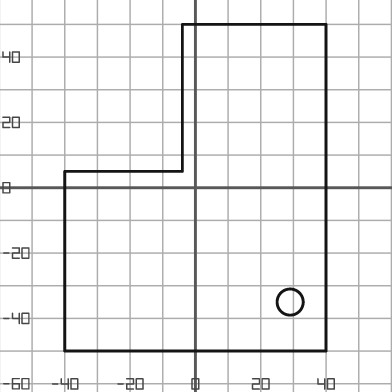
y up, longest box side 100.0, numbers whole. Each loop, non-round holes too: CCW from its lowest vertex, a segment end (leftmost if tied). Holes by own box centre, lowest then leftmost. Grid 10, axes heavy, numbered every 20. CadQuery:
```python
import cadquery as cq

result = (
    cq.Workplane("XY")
    .moveTo(-40.0, -50.0)
    .lineTo(40.0, -50.0)
    .lineTo(40.0, 50.0)
    .lineTo(-4.0, 50.0)
    .lineTo(-4.0, 5.0)
    .lineTo(-40.0, 5.0)
    .close()
    .moveTo(29.0, -35.0)
    .circle(4.0)
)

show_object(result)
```